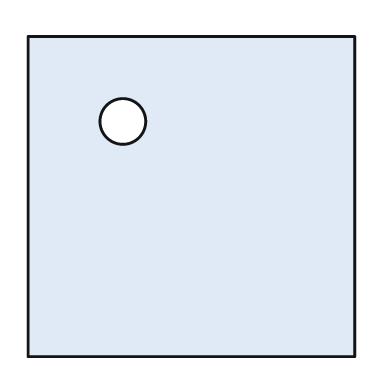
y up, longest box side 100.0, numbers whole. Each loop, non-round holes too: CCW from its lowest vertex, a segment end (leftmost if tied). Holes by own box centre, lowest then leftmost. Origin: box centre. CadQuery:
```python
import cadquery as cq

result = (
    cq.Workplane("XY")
    .moveTo(-50.0, -49.0)
    .lineTo(50.0, -49.0)
    .lineTo(50.0, 49.0)
    .lineTo(-50.0, 49.0)
    .close()
    .moveTo(-21.0, 23.0)
    .circle(7.0)
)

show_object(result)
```